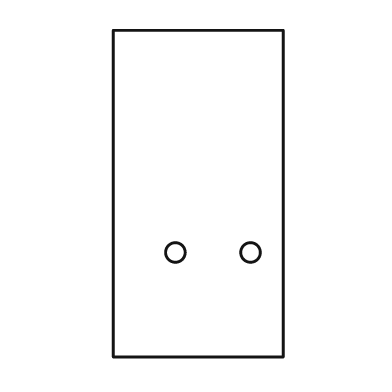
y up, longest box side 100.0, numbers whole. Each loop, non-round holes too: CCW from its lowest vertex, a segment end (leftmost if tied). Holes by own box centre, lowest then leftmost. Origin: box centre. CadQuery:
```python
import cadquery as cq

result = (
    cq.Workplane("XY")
    .moveTo(-26.0, -50.0)
    .lineTo(26.0, -50.0)
    .lineTo(26.0, 50.0)
    .lineTo(-26.0, 50.0)
    .close()
    .moveTo(-7.0, -18.0)
    .circle(3.0)
    .moveTo(16.0, -18.0)
    .circle(3.0)
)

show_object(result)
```